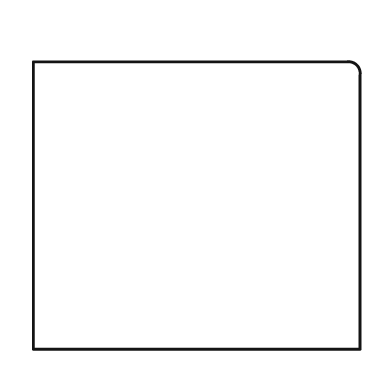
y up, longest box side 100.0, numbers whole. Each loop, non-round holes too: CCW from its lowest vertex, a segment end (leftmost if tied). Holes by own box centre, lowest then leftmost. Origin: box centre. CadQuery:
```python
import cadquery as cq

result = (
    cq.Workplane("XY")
    .moveTo(-50.0, -44.0)
    .lineTo(50.0, -44.0)
    .lineTo(50.0, 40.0)
    .threePointArc((49.0, 43.0), (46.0, 44.0))
    .lineTo(-50.0, 44.0)
    .close()
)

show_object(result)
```